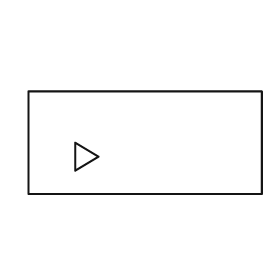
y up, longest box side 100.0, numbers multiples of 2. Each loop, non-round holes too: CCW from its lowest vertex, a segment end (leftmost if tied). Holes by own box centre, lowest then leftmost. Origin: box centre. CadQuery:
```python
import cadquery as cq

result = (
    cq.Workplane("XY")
    .moveTo(-50.0, -22.0)
    .lineTo(50.0, -22.0)
    .lineTo(50.0, 22.0)
    .lineTo(-50.0, 22.0)
    .close()
    .moveTo(-30.0, -12.0)
    .lineTo(-20.0, -6.0)
    .lineTo(-30.0, 0.0)
    .close()
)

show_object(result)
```